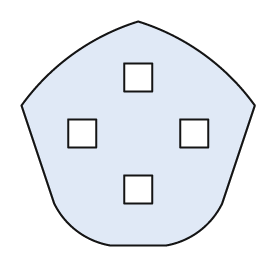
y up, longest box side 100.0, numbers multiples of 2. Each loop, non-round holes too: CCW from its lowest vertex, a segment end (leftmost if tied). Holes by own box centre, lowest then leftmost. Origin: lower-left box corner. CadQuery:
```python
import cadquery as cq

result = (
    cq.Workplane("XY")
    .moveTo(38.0, 0.0)
    .lineTo(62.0, 0.0)
    .threePointArc((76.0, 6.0), (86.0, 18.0))
    .lineTo(100.0, 60.0)
    .threePointArc((78.0, 82.0), (50.0, 96.0))
    .threePointArc((22.0, 82.0), (0.0, 60.0))
    .lineTo(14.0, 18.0)
    .threePointArc((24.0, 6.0), (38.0, 0.0))
    .close()
    .moveTo(44.0, 18.0)
    .lineTo(56.0, 18.0)
    .lineTo(56.0, 30.0)
    .lineTo(44.0, 30.0)
    .close()
    .moveTo(20.0, 42.0)
    .lineTo(32.0, 42.0)
    .lineTo(32.0, 54.0)
    .lineTo(20.0, 54.0)
    .close()
    .moveTo(68.0, 42.0)
    .lineTo(80.0, 42.0)
    .lineTo(80.0, 54.0)
    .lineTo(68.0, 54.0)
    .close()
    .moveTo(44.0, 66.0)
    .lineTo(56.0, 66.0)
    .lineTo(56.0, 78.0)
    .lineTo(44.0, 78.0)
    .close()
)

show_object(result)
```